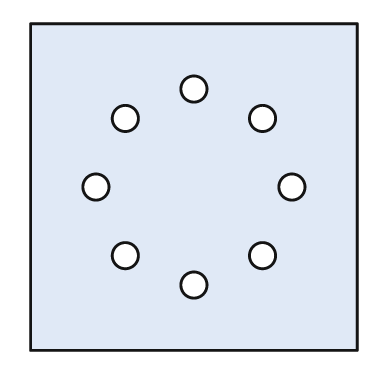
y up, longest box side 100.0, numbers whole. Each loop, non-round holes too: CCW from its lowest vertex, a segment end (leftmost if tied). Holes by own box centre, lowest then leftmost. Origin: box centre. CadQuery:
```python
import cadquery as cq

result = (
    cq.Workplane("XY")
    .moveTo(-50.0, -50.0)
    .lineTo(50.0, -50.0)
    .lineTo(50.0, 50.0)
    .lineTo(-50.0, 50.0)
    .close()
    .moveTo(0.0, -30.0)
    .circle(4.0)
    .moveTo(-21.0, -21.0)
    .circle(4.0)
    .moveTo(21.0, -21.0)
    .circle(4.0)
    .moveTo(-30.0, 0.0)
    .circle(4.0)
    .moveTo(30.0, 0.0)
    .circle(4.0)
    .moveTo(-21.0, 21.0)
    .circle(4.0)
    .moveTo(21.0, 21.0)
    .circle(4.0)
    .moveTo(0.0, 30.0)
    .circle(4.0)
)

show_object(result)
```